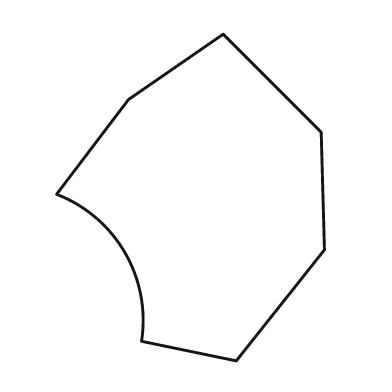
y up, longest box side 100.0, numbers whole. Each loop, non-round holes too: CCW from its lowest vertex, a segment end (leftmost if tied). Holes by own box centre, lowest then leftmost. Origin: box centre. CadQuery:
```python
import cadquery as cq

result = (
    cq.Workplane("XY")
    .moveTo(14.0, -50.0)
    .lineTo(41.0, -16.0)
    .lineTo(40.0, 20.0)
    .lineTo(10.0, 50.0)
    .lineTo(-19.0, 30.0)
    .lineTo(-41.0, 1.0)
    .threePointArc((-20.0, -17.0), (-15.0, -44.0))
    .close()
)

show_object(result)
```